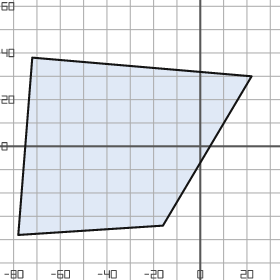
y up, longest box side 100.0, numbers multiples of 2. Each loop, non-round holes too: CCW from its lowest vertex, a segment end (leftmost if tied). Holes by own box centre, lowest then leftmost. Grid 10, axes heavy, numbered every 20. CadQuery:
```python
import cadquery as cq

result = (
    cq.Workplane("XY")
    .moveTo(-78.0, -38.0)
    .lineTo(-16.0, -34.0)
    .lineTo(22.0, 30.0)
    .lineTo(-72.0, 38.0)
    .close()
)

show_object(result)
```